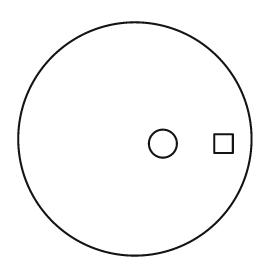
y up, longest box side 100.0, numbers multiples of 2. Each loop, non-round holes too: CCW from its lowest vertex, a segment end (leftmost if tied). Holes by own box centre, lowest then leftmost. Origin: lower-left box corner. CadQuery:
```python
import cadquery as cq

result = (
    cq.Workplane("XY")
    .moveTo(50.0, 50.0)
    .circle(50.0)
    .moveTo(62.0, 48.0)
    .circle(6.0)
    .moveTo(84.0, 44.0)
    .lineTo(92.0, 44.0)
    .lineTo(92.0, 52.0)
    .lineTo(84.0, 52.0)
    .close()
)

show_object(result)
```